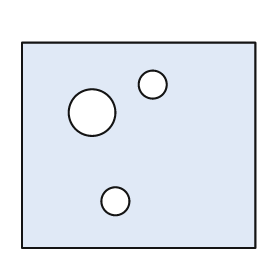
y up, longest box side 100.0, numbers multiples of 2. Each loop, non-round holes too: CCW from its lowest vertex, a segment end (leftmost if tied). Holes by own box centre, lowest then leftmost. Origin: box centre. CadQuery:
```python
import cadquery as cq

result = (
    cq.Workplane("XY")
    .moveTo(-50.0, -44.0)
    .lineTo(50.0, -44.0)
    .lineTo(50.0, 44.0)
    .lineTo(-50.0, 44.0)
    .close()
    .moveTo(-10.0, -24.0)
    .circle(6.0)
    .moveTo(-20.0, 14.0)
    .circle(10.0)
    .moveTo(6.0, 26.0)
    .circle(6.0)
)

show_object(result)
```